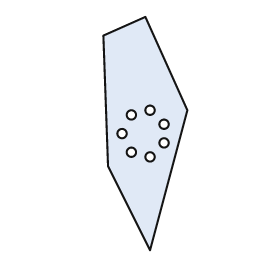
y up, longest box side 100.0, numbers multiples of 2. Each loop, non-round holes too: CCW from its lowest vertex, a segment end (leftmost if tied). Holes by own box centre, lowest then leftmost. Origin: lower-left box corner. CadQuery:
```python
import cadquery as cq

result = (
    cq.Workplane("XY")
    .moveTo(20.0, 0.0)
    .lineTo(36.0, 60.0)
    .lineTo(18.0, 100.0)
    .lineTo(0.0, 92.0)
    .lineTo(2.0, 36.0)
    .close()
    .moveTo(20.0, 40.0)
    .circle(2.0)
    .moveTo(12.0, 42.0)
    .circle(2.0)
    .moveTo(26.0, 46.0)
    .circle(2.0)
    .moveTo(8.0, 50.0)
    .circle(2.0)
    .moveTo(26.0, 54.0)
    .circle(2.0)
    .moveTo(12.0, 58.0)
    .circle(2.0)
    .moveTo(20.0, 60.0)
    .circle(2.0)
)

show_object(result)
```